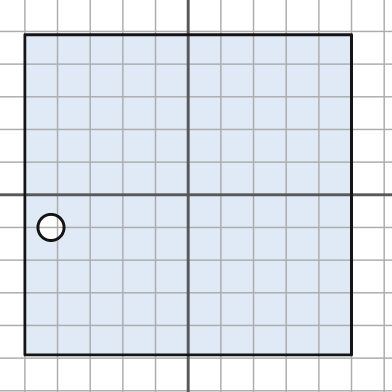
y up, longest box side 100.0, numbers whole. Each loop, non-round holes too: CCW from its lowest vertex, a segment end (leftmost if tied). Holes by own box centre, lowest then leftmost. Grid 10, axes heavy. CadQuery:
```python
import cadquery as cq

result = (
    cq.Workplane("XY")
    .moveTo(-50.0, -49.0)
    .lineTo(50.0, -49.0)
    .lineTo(50.0, 49.0)
    .lineTo(-50.0, 49.0)
    .close()
    .moveTo(-42.0, -10.0)
    .circle(4.0)
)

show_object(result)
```